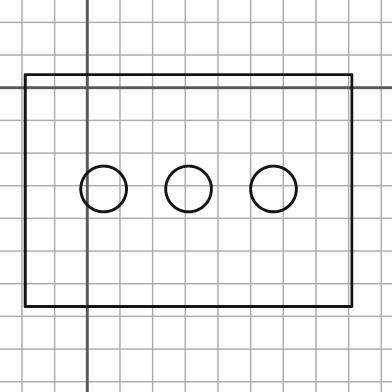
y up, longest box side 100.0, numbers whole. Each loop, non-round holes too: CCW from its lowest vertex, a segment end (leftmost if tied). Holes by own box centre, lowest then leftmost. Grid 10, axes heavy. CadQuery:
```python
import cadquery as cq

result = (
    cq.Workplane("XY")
    .moveTo(-19.0, -67.0)
    .lineTo(81.0, -67.0)
    .lineTo(81.0, 4.0)
    .lineTo(-19.0, 4.0)
    .close()
    .moveTo(5.0, -31.0)
    .circle(7.0)
    .moveTo(31.0, -31.0)
    .circle(7.0)
    .moveTo(57.0, -31.0)
    .circle(7.0)
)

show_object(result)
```